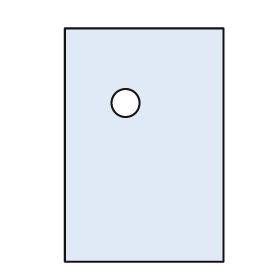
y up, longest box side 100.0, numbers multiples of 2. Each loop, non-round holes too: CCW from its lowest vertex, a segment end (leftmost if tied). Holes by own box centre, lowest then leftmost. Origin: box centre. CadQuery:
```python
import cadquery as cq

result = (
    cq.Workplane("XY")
    .moveTo(-34.0, -50.0)
    .lineTo(34.0, -50.0)
    .lineTo(34.0, 50.0)
    .lineTo(-34.0, 50.0)
    .close()
    .moveTo(-8.0, 18.0)
    .circle(6.0)
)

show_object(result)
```